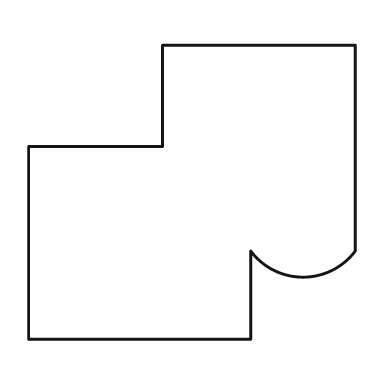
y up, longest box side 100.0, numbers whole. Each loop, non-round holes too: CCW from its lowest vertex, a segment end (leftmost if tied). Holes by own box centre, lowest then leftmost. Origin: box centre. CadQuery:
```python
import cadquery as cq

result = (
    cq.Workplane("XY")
    .moveTo(-50.0, -45.0)
    .lineTo(18.0, -45.0)
    .lineTo(18.0, -18.0)
    .threePointArc((34.0, -26.0), (50.0, -18.0))
    .lineTo(50.0, 45.0)
    .lineTo(-9.0, 45.0)
    .lineTo(-9.0, 14.0)
    .lineTo(-50.0, 14.0)
    .close()
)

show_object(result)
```